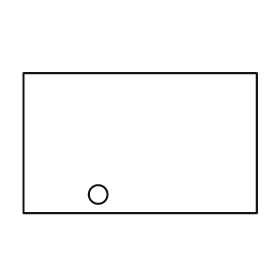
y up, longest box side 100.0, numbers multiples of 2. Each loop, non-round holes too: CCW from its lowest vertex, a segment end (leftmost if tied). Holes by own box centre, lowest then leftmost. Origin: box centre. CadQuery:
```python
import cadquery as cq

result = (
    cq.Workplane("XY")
    .moveTo(-50.0, -30.0)
    .lineTo(50.0, -30.0)
    .lineTo(50.0, 30.0)
    .lineTo(-50.0, 30.0)
    .close()
    .moveTo(-18.0, -22.0)
    .circle(4.0)
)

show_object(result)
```